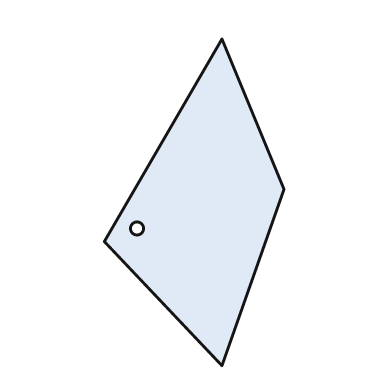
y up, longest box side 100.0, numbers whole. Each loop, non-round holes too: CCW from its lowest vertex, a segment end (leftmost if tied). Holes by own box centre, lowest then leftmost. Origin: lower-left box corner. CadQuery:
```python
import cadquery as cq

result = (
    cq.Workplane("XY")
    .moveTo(36.0, 0.0)
    .lineTo(55.0, 54.0)
    .lineTo(36.0, 100.0)
    .lineTo(0.0, 38.0)
    .close()
    .moveTo(10.0, 42.0)
    .circle(2.0)
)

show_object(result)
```